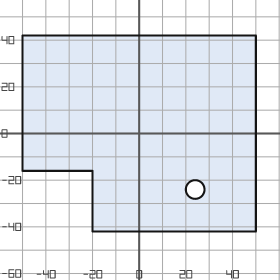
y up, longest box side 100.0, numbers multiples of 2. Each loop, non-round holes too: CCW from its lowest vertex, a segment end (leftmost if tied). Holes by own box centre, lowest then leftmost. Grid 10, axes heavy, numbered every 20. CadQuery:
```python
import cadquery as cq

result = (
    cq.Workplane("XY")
    .moveTo(-20.0, -42.0)
    .lineTo(50.0, -42.0)
    .lineTo(50.0, 42.0)
    .lineTo(-50.0, 42.0)
    .lineTo(-50.0, -16.0)
    .lineTo(-20.0, -16.0)
    .close()
    .moveTo(24.0, -24.0)
    .circle(4.0)
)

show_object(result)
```